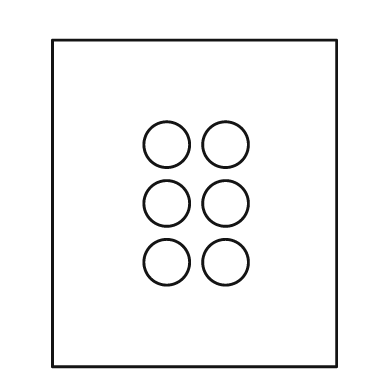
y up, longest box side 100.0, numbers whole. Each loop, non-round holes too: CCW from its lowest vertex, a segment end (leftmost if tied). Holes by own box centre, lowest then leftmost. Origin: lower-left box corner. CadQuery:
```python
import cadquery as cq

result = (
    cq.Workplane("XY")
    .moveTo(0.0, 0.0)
    .lineTo(87.0, 0.0)
    .lineTo(87.0, 100.0)
    .lineTo(0.0, 100.0)
    .close()
    .moveTo(35.0, 32.0)
    .circle(7.0)
    .moveTo(53.0, 32.0)
    .circle(7.0)
    .moveTo(35.0, 50.0)
    .circle(7.0)
    .moveTo(53.0, 50.0)
    .circle(7.0)
    .moveTo(35.0, 68.0)
    .circle(7.0)
    .moveTo(53.0, 68.0)
    .circle(7.0)
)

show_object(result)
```